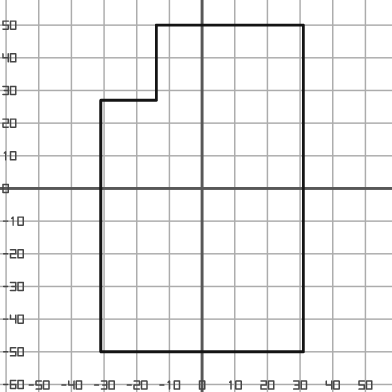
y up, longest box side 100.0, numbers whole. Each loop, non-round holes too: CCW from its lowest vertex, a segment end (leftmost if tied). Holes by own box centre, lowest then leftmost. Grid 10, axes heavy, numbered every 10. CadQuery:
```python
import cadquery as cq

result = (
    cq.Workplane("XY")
    .moveTo(-31.0, -50.0)
    .lineTo(31.0, -50.0)
    .lineTo(31.0, 50.0)
    .lineTo(-14.0, 50.0)
    .lineTo(-14.0, 27.0)
    .lineTo(-31.0, 27.0)
    .close()
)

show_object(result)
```